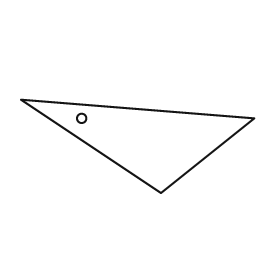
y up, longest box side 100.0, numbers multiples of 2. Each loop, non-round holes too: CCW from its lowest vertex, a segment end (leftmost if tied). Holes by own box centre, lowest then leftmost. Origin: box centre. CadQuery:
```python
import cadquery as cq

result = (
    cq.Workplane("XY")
    .moveTo(10.0, -20.0)
    .lineTo(50.0, 12.0)
    .lineTo(-50.0, 20.0)
    .close()
    .moveTo(-24.0, 12.0)
    .circle(2.0)
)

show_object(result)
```